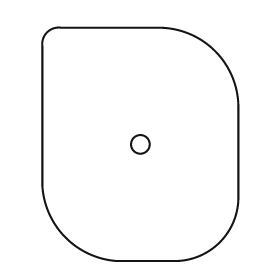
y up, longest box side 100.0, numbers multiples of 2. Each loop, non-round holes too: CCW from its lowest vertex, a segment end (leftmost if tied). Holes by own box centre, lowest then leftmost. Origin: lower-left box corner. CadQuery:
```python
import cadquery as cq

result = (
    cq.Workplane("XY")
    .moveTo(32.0, 0.0)
    .lineTo(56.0, 0.0)
    .threePointArc((76.0, 8.0), (84.0, 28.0))
    .lineTo(84.0, 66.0)
    .threePointArc((74.0, 90.0), (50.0, 100.0))
    .lineTo(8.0, 100.0)
    .threePointArc((2.0, 98.0), (0.0, 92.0))
    .lineTo(0.0, 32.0)
    .threePointArc((10.0, 10.0), (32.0, 0.0))
    .close()
    .moveTo(42.0, 50.0)
    .circle(4.0)
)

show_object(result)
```